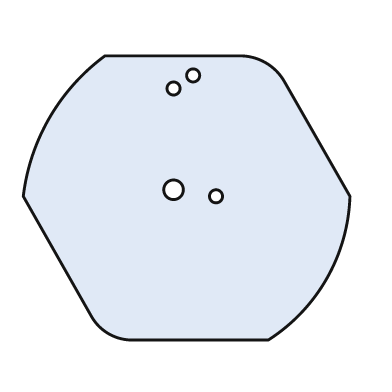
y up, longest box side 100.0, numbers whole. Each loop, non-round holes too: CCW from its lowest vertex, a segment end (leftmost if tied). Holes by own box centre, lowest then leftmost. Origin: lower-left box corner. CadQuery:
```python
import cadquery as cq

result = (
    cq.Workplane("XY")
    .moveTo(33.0, 0.0)
    .lineTo(75.0, 0.0)
    .threePointArc((93.0, 19.0), (100.0, 44.0))
    .lineTo(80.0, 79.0)
    .threePointArc((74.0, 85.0), (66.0, 87.0))
    .lineTo(25.0, 87.0)
    .threePointArc((8.0, 68.0), (0.0, 44.0))
    .lineTo(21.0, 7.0)
    .threePointArc((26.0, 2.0), (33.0, 0.0))
    .close()
    .moveTo(59.0, 44.0)
    .circle(2.0)
    .moveTo(46.0, 46.0)
    .circle(3.0)
    .moveTo(46.0, 77.0)
    .circle(2.0)
    .moveTo(52.0, 81.0)
    .circle(2.0)
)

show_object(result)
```